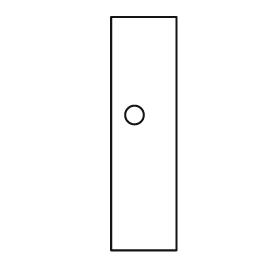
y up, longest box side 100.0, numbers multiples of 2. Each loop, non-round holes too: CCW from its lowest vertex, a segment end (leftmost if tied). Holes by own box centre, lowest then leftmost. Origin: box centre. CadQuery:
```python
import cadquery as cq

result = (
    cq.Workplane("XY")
    .moveTo(-14.0, -50.0)
    .lineTo(14.0, -50.0)
    .lineTo(14.0, 50.0)
    .lineTo(-14.0, 50.0)
    .close()
    .moveTo(-4.0, 8.0)
    .circle(4.0)
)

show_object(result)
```